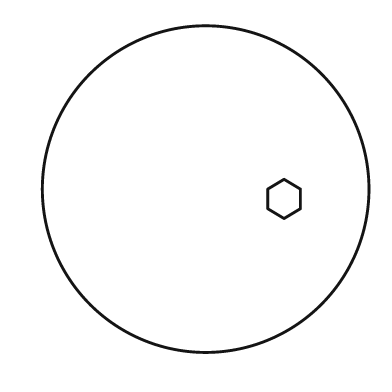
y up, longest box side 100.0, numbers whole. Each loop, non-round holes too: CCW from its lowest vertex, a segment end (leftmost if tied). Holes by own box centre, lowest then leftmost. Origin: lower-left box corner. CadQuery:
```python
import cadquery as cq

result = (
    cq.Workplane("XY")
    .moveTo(50.0, 50.0)
    .circle(50.0)
    .moveTo(74.0, 41.0)
    .lineTo(79.0, 44.0)
    .lineTo(79.0, 50.0)
    .lineTo(74.0, 53.0)
    .lineTo(69.0, 50.0)
    .lineTo(69.0, 44.0)
    .close()
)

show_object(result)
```